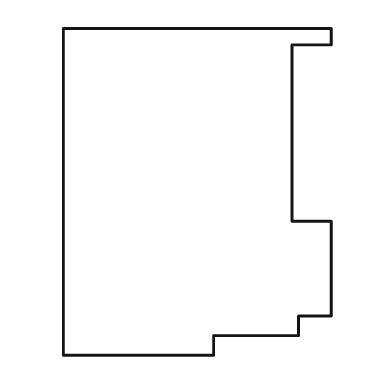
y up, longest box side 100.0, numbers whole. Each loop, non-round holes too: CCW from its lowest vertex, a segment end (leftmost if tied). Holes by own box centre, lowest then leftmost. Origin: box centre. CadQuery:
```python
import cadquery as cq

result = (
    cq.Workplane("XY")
    .moveTo(-41.0, -50.0)
    .lineTo(5.0, -50.0)
    .lineTo(5.0, -44.0)
    .lineTo(31.0, -44.0)
    .lineTo(31.0, -38.0)
    .lineTo(41.0, -38.0)
    .lineTo(41.0, -9.0)
    .lineTo(29.0, -9.0)
    .lineTo(29.0, 45.0)
    .lineTo(41.0, 45.0)
    .lineTo(41.0, 50.0)
    .lineTo(-41.0, 50.0)
    .close()
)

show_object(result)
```